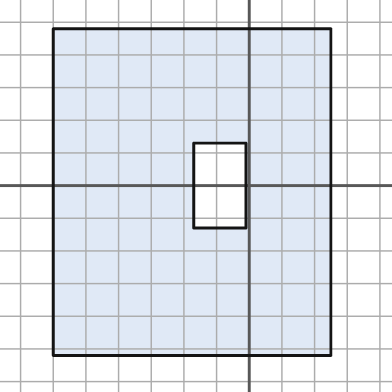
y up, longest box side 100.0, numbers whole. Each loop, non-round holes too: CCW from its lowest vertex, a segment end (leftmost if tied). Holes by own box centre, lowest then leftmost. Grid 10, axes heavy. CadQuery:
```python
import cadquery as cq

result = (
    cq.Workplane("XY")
    .moveTo(-60.0, -52.0)
    .lineTo(25.0, -52.0)
    .lineTo(25.0, 48.0)
    .lineTo(-60.0, 48.0)
    .close()
    .moveTo(-17.0, -13.0)
    .lineTo(-1.0, -13.0)
    .lineTo(-1.0, 13.0)
    .lineTo(-17.0, 13.0)
    .close()
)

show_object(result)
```